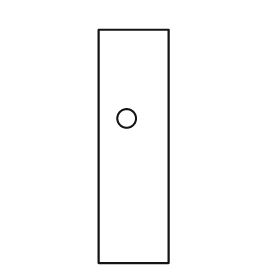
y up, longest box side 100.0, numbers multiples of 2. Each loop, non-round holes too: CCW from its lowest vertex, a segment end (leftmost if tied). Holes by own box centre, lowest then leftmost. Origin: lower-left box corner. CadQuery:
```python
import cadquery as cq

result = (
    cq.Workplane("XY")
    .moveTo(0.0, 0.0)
    .lineTo(30.0, 0.0)
    .lineTo(30.0, 100.0)
    .lineTo(0.0, 100.0)
    .close()
    .moveTo(12.0, 62.0)
    .circle(4.0)
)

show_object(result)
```